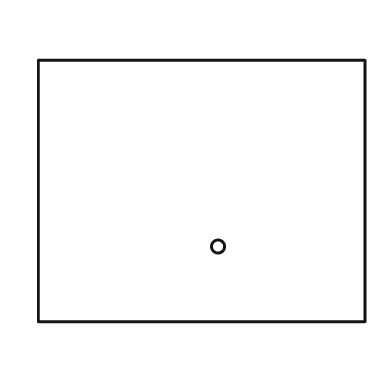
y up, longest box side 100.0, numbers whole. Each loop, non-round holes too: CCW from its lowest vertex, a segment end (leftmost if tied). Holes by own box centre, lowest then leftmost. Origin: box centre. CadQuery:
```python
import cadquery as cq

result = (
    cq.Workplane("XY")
    .moveTo(-50.0, -40.0)
    .lineTo(50.0, -40.0)
    .lineTo(50.0, 40.0)
    .lineTo(-50.0, 40.0)
    .close()
    .moveTo(5.0, -17.0)
    .circle(2.0)
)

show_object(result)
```